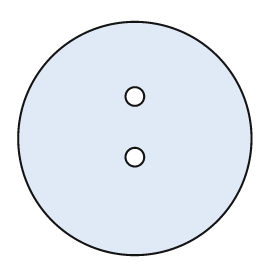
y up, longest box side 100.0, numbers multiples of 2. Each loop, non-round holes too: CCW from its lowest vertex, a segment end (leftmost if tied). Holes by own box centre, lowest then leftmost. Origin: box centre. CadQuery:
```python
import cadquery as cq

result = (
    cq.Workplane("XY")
    .moveTo(0.0, 0.0)
    .circle(50.0)
    .moveTo(0.0, -8.0)
    .circle(4.0)
    .moveTo(0.0, 18.0)
    .circle(4.0)
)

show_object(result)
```